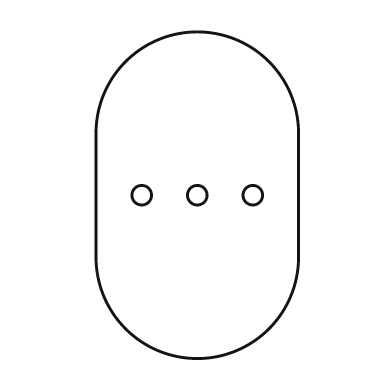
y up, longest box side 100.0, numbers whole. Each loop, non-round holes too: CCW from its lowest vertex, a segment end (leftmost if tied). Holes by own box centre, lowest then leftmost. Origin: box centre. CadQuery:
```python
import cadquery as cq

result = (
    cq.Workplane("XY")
    .moveTo(-31.0, -19.0)
    .threePointArc((0.0, -50.0), (31.0, -19.0))
    .lineTo(31.0, 19.0)
    .threePointArc((0.0, 50.0), (-31.0, 19.0))
    .close()
    .moveTo(-17.0, 0.0)
    .circle(3.0)
    .moveTo(0.0, 0.0)
    .circle(3.0)
    .moveTo(17.0, 0.0)
    .circle(3.0)
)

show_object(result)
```